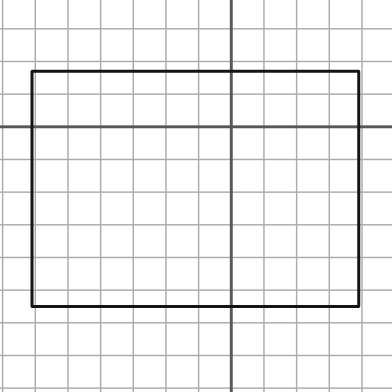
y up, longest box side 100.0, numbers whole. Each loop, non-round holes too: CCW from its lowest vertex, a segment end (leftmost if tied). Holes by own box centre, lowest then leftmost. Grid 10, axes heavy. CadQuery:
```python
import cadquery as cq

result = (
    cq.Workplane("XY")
    .moveTo(-61.0, -55.0)
    .lineTo(39.0, -55.0)
    .lineTo(39.0, 17.0)
    .lineTo(-61.0, 17.0)
    .close()
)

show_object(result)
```